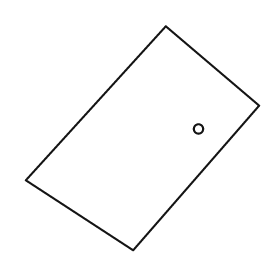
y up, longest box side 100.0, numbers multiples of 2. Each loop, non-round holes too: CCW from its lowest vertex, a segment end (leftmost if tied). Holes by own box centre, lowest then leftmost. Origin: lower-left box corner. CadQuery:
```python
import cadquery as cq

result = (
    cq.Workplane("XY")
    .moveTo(46.0, 0.0)
    .lineTo(100.0, 62.0)
    .lineTo(60.0, 96.0)
    .lineTo(0.0, 30.0)
    .close()
    .moveTo(74.0, 52.0)
    .circle(2.0)
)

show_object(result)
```